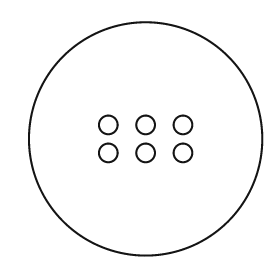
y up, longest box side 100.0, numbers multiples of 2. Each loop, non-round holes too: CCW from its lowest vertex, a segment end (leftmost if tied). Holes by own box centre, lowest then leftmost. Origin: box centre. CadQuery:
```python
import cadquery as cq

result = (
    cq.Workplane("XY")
    .moveTo(0.0, 0.0)
    .circle(50.0)
    .moveTo(-16.0, -6.0)
    .circle(4.0)
    .moveTo(0.0, -6.0)
    .circle(4.0)
    .moveTo(16.0, -6.0)
    .circle(4.0)
    .moveTo(-16.0, 6.0)
    .circle(4.0)
    .moveTo(0.0, 6.0)
    .circle(4.0)
    .moveTo(16.0, 6.0)
    .circle(4.0)
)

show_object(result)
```